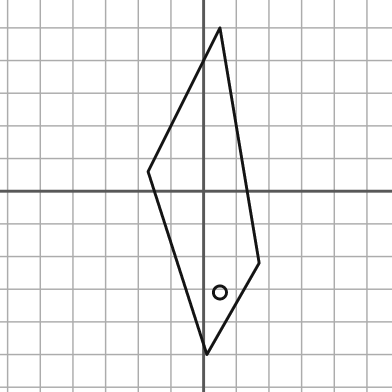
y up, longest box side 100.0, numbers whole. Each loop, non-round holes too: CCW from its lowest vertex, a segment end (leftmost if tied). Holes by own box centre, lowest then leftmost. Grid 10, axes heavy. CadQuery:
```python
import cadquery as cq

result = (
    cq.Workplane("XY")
    .moveTo(1.0, -50.0)
    .lineTo(17.0, -22.0)
    .lineTo(5.0, 50.0)
    .lineTo(-17.0, 6.0)
    .close()
    .moveTo(5.0, -31.0)
    .circle(2.0)
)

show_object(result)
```